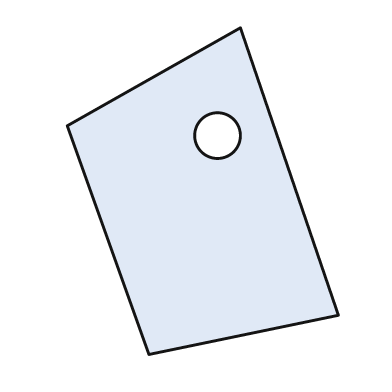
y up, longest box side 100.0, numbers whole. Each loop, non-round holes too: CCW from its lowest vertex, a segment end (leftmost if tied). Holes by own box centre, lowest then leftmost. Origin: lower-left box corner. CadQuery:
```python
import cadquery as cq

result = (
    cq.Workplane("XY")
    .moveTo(25.0, 0.0)
    .lineTo(83.0, 12.0)
    .lineTo(53.0, 100.0)
    .lineTo(0.0, 70.0)
    .close()
    .moveTo(46.0, 67.0)
    .circle(7.0)
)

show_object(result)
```